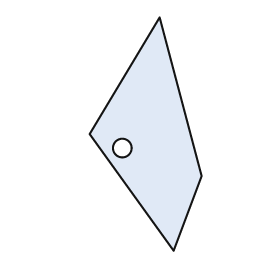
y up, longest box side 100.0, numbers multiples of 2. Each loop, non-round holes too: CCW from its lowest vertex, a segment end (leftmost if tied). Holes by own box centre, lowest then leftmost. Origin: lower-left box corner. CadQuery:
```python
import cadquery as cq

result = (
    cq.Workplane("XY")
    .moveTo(36.0, 0.0)
    .lineTo(48.0, 32.0)
    .lineTo(30.0, 100.0)
    .lineTo(0.0, 50.0)
    .close()
    .moveTo(14.0, 44.0)
    .circle(4.0)
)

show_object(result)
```